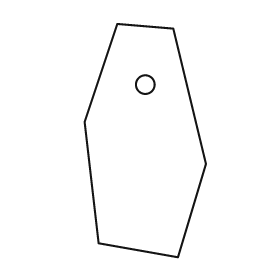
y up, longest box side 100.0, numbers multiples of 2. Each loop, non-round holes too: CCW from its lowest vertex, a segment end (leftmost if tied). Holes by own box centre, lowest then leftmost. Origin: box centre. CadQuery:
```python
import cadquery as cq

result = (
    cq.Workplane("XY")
    .moveTo(14.0, -50.0)
    .lineTo(26.0, -10.0)
    .lineTo(12.0, 48.0)
    .lineTo(-12.0, 50.0)
    .lineTo(-26.0, 8.0)
    .lineTo(-20.0, -44.0)
    .close()
    .moveTo(0.0, 24.0)
    .circle(4.0)
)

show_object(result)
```